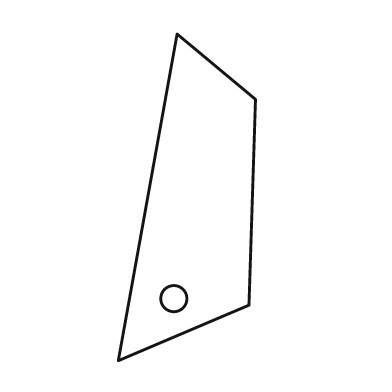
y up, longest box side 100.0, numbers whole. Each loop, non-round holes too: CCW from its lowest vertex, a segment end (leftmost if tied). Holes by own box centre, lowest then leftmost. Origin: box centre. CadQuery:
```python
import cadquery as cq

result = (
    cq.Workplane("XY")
    .moveTo(-21.0, -50.0)
    .lineTo(19.0, -33.0)
    .lineTo(21.0, 30.0)
    .lineTo(-3.0, 50.0)
    .close()
    .moveTo(-4.0, -31.0)
    .circle(4.0)
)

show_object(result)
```